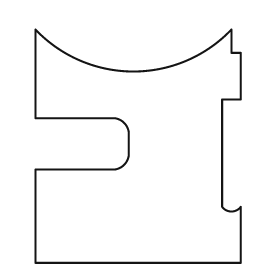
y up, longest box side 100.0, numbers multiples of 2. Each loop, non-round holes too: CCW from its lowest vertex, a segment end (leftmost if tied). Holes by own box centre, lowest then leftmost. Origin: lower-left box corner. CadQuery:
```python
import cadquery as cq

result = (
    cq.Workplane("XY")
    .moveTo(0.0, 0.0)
    .lineTo(88.0, 0.0)
    .lineTo(88.0, 24.0)
    .threePointArc((84.0, 22.0), (80.0, 24.0))
    .lineTo(80.0, 70.0)
    .lineTo(88.0, 70.0)
    .lineTo(88.0, 90.0)
    .lineTo(84.0, 90.0)
    .lineTo(84.0, 100.0)
    .threePointArc((42.0, 82.0), (0.0, 100.0))
    .lineTo(0.0, 62.0)
    .lineTo(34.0, 62.0)
    .threePointArc((38.0, 60.0), (40.0, 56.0))
    .lineTo(40.0, 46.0)
    .threePointArc((38.0, 42.0), (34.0, 40.0))
    .lineTo(0.0, 40.0)
    .close()
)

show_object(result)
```